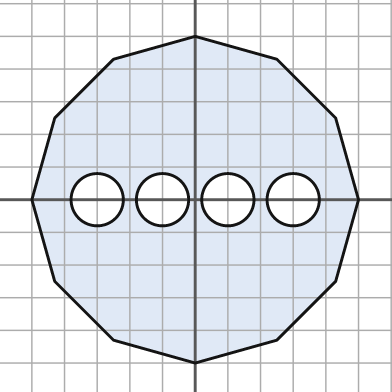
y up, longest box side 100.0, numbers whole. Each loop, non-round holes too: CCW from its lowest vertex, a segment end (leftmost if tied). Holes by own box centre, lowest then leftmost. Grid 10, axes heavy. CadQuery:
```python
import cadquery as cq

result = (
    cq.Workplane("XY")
    .moveTo(0.0, -50.0)
    .lineTo(25.0, -43.0)
    .lineTo(43.0, -25.0)
    .lineTo(50.0, 0.0)
    .lineTo(43.0, 25.0)
    .lineTo(25.0, 43.0)
    .lineTo(0.0, 50.0)
    .lineTo(-25.0, 43.0)
    .lineTo(-43.0, 25.0)
    .lineTo(-50.0, 0.0)
    .lineTo(-43.0, -25.0)
    .lineTo(-25.0, -43.0)
    .close()
    .moveTo(-30.0, 0.0)
    .circle(8.0)
    .moveTo(-10.0, 0.0)
    .circle(8.0)
    .moveTo(10.0, 0.0)
    .circle(8.0)
    .moveTo(30.0, 0.0)
    .circle(8.0)
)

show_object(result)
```